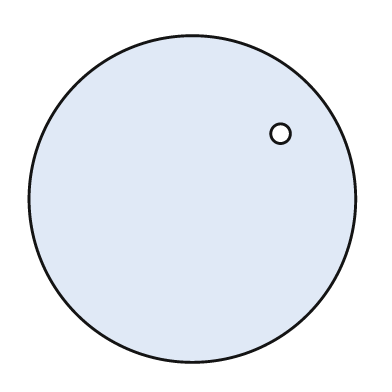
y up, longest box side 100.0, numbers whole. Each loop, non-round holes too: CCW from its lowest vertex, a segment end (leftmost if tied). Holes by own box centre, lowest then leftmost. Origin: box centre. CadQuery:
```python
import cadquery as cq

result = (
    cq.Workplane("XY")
    .moveTo(0.0, 0.0)
    .circle(50.0)
    .moveTo(27.0, 20.0)
    .circle(3.0)
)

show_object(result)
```